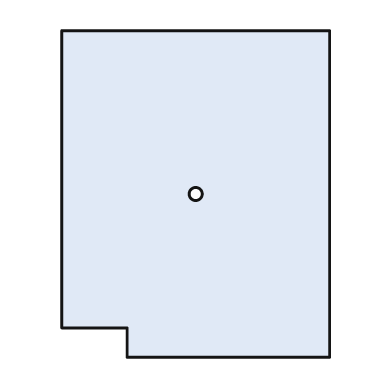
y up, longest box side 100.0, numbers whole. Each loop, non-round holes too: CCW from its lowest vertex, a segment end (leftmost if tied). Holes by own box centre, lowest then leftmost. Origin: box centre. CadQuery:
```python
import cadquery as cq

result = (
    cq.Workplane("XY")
    .moveTo(-21.0, -50.0)
    .lineTo(41.0, -50.0)
    .lineTo(41.0, 50.0)
    .lineTo(-41.0, 50.0)
    .lineTo(-41.0, -41.0)
    .lineTo(-21.0, -41.0)
    .close()
    .moveTo(0.0, 0.0)
    .circle(2.0)
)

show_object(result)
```